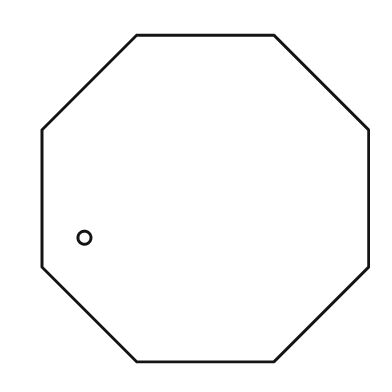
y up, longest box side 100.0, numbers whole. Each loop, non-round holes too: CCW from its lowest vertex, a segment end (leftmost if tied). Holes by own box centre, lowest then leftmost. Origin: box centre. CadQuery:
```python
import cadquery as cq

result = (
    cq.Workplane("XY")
    .moveTo(-21.0, -50.0)
    .lineTo(21.0, -50.0)
    .lineTo(50.0, -21.0)
    .lineTo(50.0, 21.0)
    .lineTo(21.0, 50.0)
    .lineTo(-21.0, 50.0)
    .lineTo(-50.0, 21.0)
    .lineTo(-50.0, -21.0)
    .close()
    .moveTo(-37.0, -12.0)
    .circle(2.0)
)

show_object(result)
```